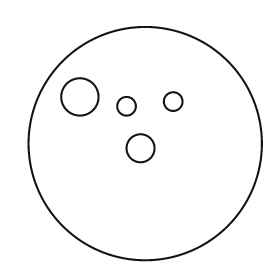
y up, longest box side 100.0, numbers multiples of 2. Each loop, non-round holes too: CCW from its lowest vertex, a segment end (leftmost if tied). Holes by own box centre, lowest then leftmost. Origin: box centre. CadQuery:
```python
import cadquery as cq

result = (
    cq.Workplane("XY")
    .moveTo(0.0, 0.0)
    .circle(50.0)
    .moveTo(-2.0, -2.0)
    .circle(6.0)
    .moveTo(-8.0, 16.0)
    .circle(4.0)
    .moveTo(12.0, 18.0)
    .circle(4.0)
    .moveTo(-28.0, 20.0)
    .circle(8.0)
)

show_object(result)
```